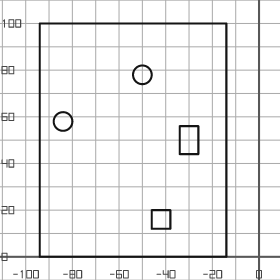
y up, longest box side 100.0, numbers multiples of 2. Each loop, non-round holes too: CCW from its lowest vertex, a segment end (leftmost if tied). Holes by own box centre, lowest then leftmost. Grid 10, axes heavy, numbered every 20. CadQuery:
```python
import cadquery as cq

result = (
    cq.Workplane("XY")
    .moveTo(-94.0, 0.0)
    .lineTo(-14.0, 0.0)
    .lineTo(-14.0, 100.0)
    .lineTo(-94.0, 100.0)
    .close()
    .moveTo(-46.0, 12.0)
    .lineTo(-38.0, 12.0)
    .lineTo(-38.0, 20.0)
    .lineTo(-46.0, 20.0)
    .close()
    .moveTo(-34.0, 44.0)
    .lineTo(-26.0, 44.0)
    .lineTo(-26.0, 56.0)
    .lineTo(-34.0, 56.0)
    .close()
    .moveTo(-84.0, 58.0)
    .circle(4.0)
    .moveTo(-50.0, 78.0)
    .circle(4.0)
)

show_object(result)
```